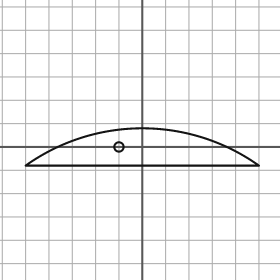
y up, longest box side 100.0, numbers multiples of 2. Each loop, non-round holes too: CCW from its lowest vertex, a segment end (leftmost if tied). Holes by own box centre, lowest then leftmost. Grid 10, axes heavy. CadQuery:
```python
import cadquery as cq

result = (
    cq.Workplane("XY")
    .moveTo(-50.0, -8.0)
    .lineTo(50.0, -8.0)
    .threePointArc((0.0, 8.0), (-50.0, -8.0))
    .close()
    .moveTo(-10.0, 0.0)
    .circle(2.0)
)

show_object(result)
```